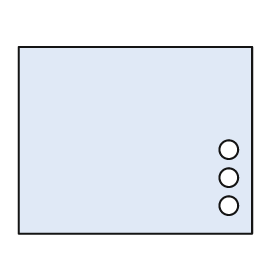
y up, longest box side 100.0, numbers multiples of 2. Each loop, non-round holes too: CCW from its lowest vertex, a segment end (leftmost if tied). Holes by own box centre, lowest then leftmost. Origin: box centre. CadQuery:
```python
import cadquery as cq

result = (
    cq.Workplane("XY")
    .moveTo(-50.0, -40.0)
    .lineTo(50.0, -40.0)
    .lineTo(50.0, 40.0)
    .lineTo(-50.0, 40.0)
    .close()
    .moveTo(40.0, -28.0)
    .circle(4.0)
    .moveTo(40.0, -16.0)
    .circle(4.0)
    .moveTo(40.0, -4.0)
    .circle(4.0)
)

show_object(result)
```